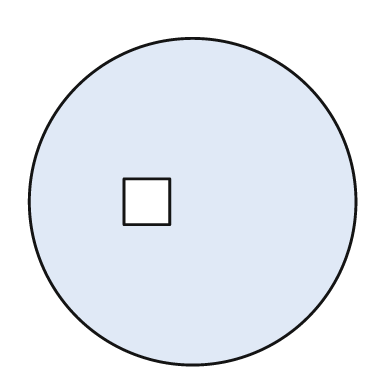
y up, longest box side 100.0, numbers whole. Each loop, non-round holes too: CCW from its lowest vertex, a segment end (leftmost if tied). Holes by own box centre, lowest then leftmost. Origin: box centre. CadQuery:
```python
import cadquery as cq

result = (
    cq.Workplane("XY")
    .moveTo(0.0, 0.0)
    .circle(50.0)
    .moveTo(-21.0, -7.0)
    .lineTo(-7.0, -7.0)
    .lineTo(-7.0, 7.0)
    .lineTo(-21.0, 7.0)
    .close()
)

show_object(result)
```